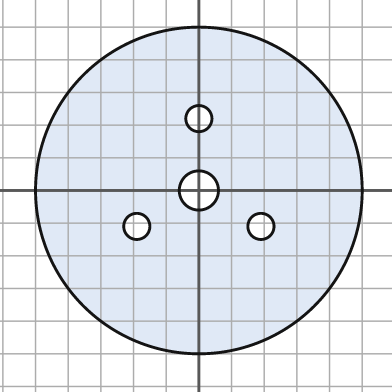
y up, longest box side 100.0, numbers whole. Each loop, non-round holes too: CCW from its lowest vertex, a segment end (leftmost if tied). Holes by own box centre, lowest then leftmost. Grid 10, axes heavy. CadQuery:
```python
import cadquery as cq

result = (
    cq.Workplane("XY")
    .moveTo(0.0, 0.0)
    .circle(50.0)
    .moveTo(-19.0, -11.0)
    .circle(4.0)
    .moveTo(19.0, -11.0)
    .circle(4.0)
    .moveTo(0.0, 0.0)
    .circle(6.0)
    .moveTo(0.0, 22.0)
    .circle(4.0)
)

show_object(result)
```